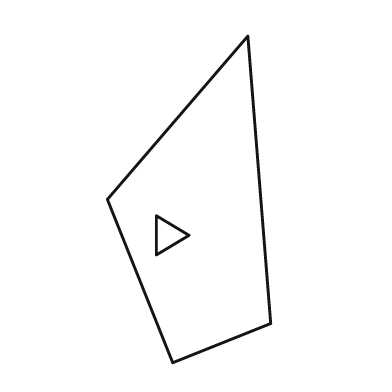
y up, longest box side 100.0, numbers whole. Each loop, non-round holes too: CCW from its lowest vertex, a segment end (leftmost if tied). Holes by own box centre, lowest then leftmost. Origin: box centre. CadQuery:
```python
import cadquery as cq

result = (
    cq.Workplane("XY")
    .moveTo(-5.0, -50.0)
    .lineTo(25.0, -38.0)
    .lineTo(18.0, 50.0)
    .lineTo(-25.0, 0.0)
    .close()
    .moveTo(-10.0, -17.0)
    .lineTo(0.0, -11.0)
    .lineTo(-10.0, -5.0)
    .close()
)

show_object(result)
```